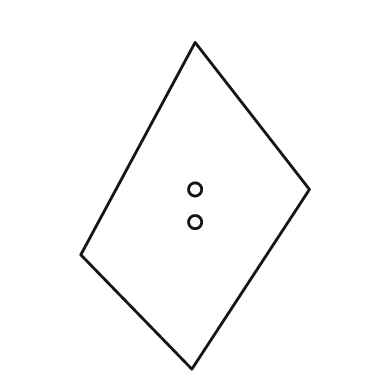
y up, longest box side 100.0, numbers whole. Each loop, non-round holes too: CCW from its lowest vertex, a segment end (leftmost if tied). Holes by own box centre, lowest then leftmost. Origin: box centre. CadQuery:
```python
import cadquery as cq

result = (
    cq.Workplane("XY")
    .moveTo(-1.0, -50.0)
    .lineTo(35.0, 5.0)
    .lineTo(0.0, 50.0)
    .lineTo(-35.0, -15.0)
    .close()
    .moveTo(0.0, -5.0)
    .circle(2.0)
    .moveTo(0.0, 5.0)
    .circle(2.0)
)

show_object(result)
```